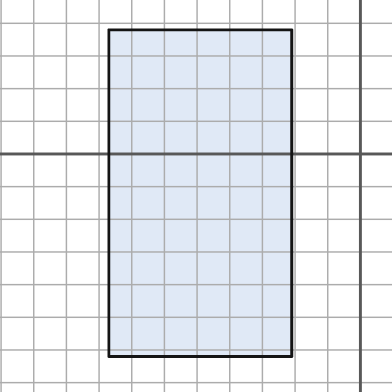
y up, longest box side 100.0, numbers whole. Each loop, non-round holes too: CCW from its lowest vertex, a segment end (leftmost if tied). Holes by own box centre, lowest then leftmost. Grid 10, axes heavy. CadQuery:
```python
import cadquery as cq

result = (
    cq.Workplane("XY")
    .moveTo(-77.0, -62.0)
    .lineTo(-21.0, -62.0)
    .lineTo(-21.0, 38.0)
    .lineTo(-77.0, 38.0)
    .close()
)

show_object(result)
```